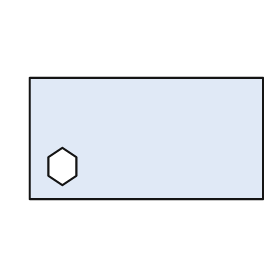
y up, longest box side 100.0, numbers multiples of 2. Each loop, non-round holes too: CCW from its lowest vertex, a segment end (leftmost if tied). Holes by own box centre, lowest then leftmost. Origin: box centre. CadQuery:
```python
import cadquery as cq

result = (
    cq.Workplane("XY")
    .moveTo(-50.0, -26.0)
    .lineTo(50.0, -26.0)
    .lineTo(50.0, 26.0)
    .lineTo(-50.0, 26.0)
    .close()
    .moveTo(-36.0, -20.0)
    .lineTo(-30.0, -16.0)
    .lineTo(-30.0, -8.0)
    .lineTo(-36.0, -4.0)
    .lineTo(-42.0, -8.0)
    .lineTo(-42.0, -16.0)
    .close()
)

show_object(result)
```